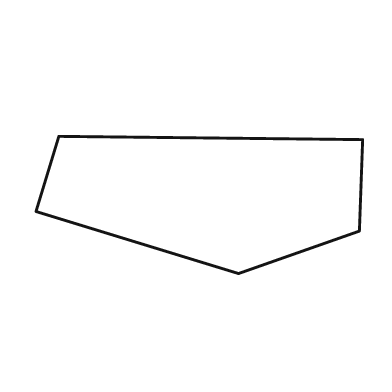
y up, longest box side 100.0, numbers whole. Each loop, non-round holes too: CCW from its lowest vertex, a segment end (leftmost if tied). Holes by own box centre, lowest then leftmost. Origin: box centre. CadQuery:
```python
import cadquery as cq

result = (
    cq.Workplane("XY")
    .moveTo(12.0, -21.0)
    .lineTo(49.0, -8.0)
    .lineTo(50.0, 20.0)
    .lineTo(-43.0, 21.0)
    .lineTo(-50.0, -2.0)
    .close()
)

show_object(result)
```